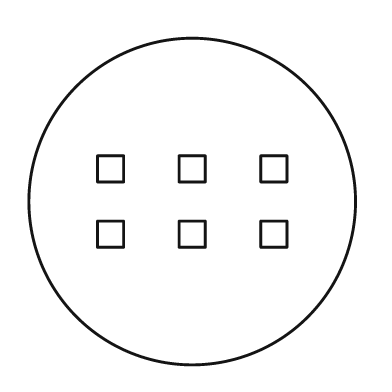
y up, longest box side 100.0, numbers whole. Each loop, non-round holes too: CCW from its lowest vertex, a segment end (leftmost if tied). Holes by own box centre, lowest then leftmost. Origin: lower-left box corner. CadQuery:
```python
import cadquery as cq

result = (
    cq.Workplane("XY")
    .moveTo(50.0, 50.0)
    .circle(50.0)
    .moveTo(21.0, 36.0)
    .lineTo(29.0, 36.0)
    .lineTo(29.0, 44.0)
    .lineTo(21.0, 44.0)
    .close()
    .moveTo(46.0, 36.0)
    .lineTo(54.0, 36.0)
    .lineTo(54.0, 44.0)
    .lineTo(46.0, 44.0)
    .close()
    .moveTo(71.0, 36.0)
    .lineTo(79.0, 36.0)
    .lineTo(79.0, 44.0)
    .lineTo(71.0, 44.0)
    .close()
    .moveTo(21.0, 56.0)
    .lineTo(29.0, 56.0)
    .lineTo(29.0, 64.0)
    .lineTo(21.0, 64.0)
    .close()
    .moveTo(46.0, 56.0)
    .lineTo(54.0, 56.0)
    .lineTo(54.0, 64.0)
    .lineTo(46.0, 64.0)
    .close()
    .moveTo(71.0, 56.0)
    .lineTo(79.0, 56.0)
    .lineTo(79.0, 64.0)
    .lineTo(71.0, 64.0)
    .close()
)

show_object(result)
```